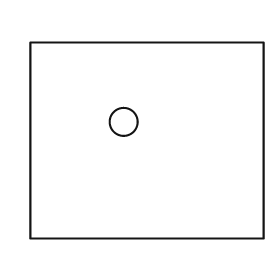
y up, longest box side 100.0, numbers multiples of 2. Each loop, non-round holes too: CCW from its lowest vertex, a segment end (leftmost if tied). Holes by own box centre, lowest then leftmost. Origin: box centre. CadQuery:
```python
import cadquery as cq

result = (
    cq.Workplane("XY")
    .moveTo(-50.0, -42.0)
    .lineTo(50.0, -42.0)
    .lineTo(50.0, 42.0)
    .lineTo(-50.0, 42.0)
    .close()
    .moveTo(-10.0, 8.0)
    .circle(6.0)
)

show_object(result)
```